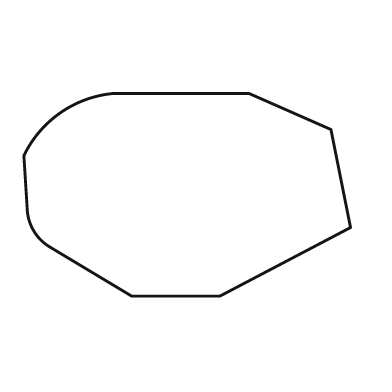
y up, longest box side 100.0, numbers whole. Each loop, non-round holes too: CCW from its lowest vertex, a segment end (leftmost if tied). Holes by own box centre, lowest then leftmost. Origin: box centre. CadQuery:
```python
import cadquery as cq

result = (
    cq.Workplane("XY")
    .moveTo(-17.0, -31.0)
    .lineTo(10.0, -31.0)
    .lineTo(50.0, -10.0)
    .lineTo(44.0, 20.0)
    .lineTo(19.0, 31.0)
    .lineTo(-23.0, 31.0)
    .threePointArc((-39.0, 25.0), (-50.0, 12.0))
    .lineTo(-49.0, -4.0)
    .threePointArc((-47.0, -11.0), (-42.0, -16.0))
    .close()
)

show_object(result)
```